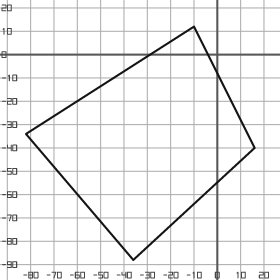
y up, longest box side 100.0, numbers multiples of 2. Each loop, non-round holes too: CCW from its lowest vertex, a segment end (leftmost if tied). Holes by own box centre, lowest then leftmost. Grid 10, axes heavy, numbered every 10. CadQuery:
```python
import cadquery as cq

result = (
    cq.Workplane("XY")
    .moveTo(-36.0, -88.0)
    .lineTo(16.0, -40.0)
    .lineTo(-10.0, 12.0)
    .lineTo(-82.0, -34.0)
    .close()
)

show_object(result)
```